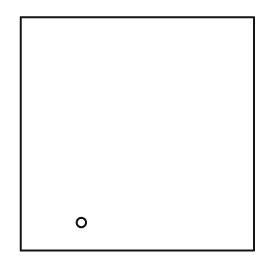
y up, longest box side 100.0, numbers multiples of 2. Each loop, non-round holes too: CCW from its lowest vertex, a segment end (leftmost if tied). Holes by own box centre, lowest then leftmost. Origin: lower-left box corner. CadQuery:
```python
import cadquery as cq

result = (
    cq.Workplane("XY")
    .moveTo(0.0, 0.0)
    .lineTo(100.0, 0.0)
    .lineTo(100.0, 100.0)
    .lineTo(0.0, 100.0)
    .close()
    .moveTo(26.0, 12.0)
    .circle(2.0)
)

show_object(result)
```